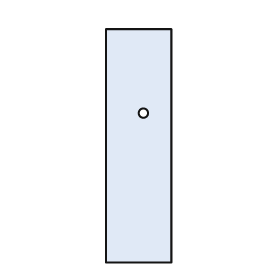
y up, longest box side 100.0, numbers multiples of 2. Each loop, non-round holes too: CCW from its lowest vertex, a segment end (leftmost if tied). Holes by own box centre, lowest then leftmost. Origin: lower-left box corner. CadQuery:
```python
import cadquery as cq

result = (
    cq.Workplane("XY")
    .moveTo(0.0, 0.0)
    .lineTo(28.0, 0.0)
    .lineTo(28.0, 100.0)
    .lineTo(0.0, 100.0)
    .close()
    .moveTo(16.0, 64.0)
    .circle(2.0)
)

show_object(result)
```